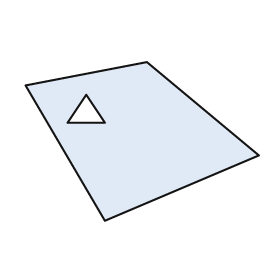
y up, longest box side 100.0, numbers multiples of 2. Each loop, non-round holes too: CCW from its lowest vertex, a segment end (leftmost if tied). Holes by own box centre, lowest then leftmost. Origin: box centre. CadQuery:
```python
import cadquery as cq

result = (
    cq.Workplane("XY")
    .moveTo(-16.0, -34.0)
    .lineTo(50.0, -6.0)
    .lineTo(2.0, 34.0)
    .lineTo(-50.0, 24.0)
    .close()
    .moveTo(-32.0, 8.0)
    .lineTo(-16.0, 8.0)
    .lineTo(-24.0, 20.0)
    .close()
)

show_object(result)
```